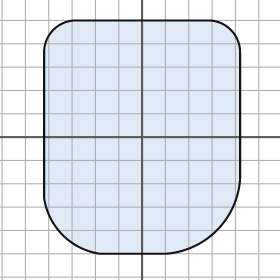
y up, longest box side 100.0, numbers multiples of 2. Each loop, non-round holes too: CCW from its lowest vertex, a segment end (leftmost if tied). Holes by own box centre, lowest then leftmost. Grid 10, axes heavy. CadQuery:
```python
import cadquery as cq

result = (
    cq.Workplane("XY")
    .moveTo(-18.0, -50.0)
    .lineTo(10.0, -50.0)
    .threePointArc((32.0, -40.0), (42.0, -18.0))
    .lineTo(42.0, 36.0)
    .threePointArc((38.0, 46.0), (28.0, 50.0))
    .lineTo(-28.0, 50.0)
    .threePointArc((-38.0, 46.0), (-42.0, 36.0))
    .lineTo(-42.0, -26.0)
    .threePointArc((-34.0, -42.0), (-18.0, -50.0))
    .close()
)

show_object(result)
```